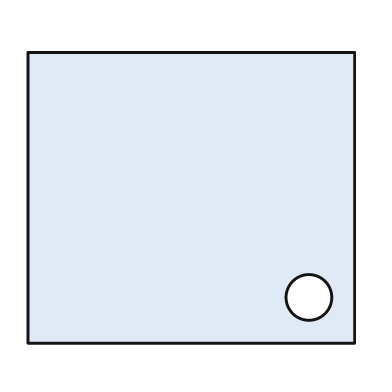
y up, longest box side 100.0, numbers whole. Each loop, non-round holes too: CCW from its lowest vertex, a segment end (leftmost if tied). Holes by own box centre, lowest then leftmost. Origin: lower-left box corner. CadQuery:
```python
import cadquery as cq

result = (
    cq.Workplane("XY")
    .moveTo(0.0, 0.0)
    .lineTo(100.0, 0.0)
    .lineTo(100.0, 89.0)
    .lineTo(0.0, 89.0)
    .close()
    .moveTo(86.0, 14.0)
    .circle(7.0)
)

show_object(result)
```